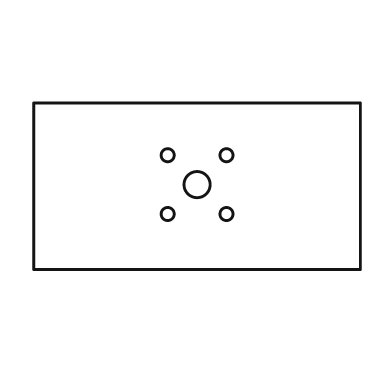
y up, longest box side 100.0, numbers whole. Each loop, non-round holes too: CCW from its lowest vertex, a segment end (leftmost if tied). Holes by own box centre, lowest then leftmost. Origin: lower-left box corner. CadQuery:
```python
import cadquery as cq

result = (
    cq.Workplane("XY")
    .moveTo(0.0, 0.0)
    .lineTo(100.0, 0.0)
    .lineTo(100.0, 51.0)
    .lineTo(0.0, 51.0)
    .close()
    .moveTo(41.0, 17.0)
    .circle(2.0)
    .moveTo(59.0, 17.0)
    .circle(2.0)
    .moveTo(50.0, 26.0)
    .circle(4.0)
    .moveTo(41.0, 35.0)
    .circle(2.0)
    .moveTo(59.0, 35.0)
    .circle(2.0)
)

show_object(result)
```